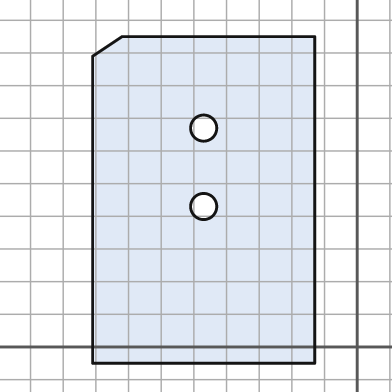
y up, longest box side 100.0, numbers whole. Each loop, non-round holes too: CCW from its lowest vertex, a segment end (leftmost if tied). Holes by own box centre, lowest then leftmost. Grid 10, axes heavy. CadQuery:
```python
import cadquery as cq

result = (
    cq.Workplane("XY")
    .moveTo(-81.0, -5.0)
    .lineTo(-13.0, -5.0)
    .lineTo(-13.0, 95.0)
    .lineTo(-72.0, 95.0)
    .lineTo(-81.0, 89.0)
    .close()
    .moveTo(-47.0, 43.0)
    .circle(4.0)
    .moveTo(-47.0, 67.0)
    .circle(4.0)
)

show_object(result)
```